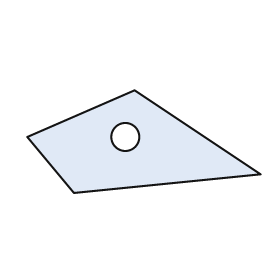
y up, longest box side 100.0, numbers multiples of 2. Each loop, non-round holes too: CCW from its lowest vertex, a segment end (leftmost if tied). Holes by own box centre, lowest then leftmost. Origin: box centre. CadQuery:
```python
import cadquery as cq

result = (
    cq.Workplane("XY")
    .moveTo(-30.0, -22.0)
    .lineTo(50.0, -14.0)
    .lineTo(-4.0, 22.0)
    .lineTo(-50.0, 2.0)
    .close()
    .moveTo(-8.0, 2.0)
    .circle(6.0)
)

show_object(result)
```